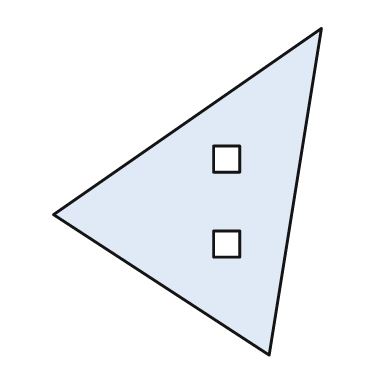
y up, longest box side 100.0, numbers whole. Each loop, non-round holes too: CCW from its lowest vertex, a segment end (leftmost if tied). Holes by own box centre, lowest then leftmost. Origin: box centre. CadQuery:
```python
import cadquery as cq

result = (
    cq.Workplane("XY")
    .moveTo(25.0, -50.0)
    .lineTo(41.0, 50.0)
    .lineTo(-41.0, -7.0)
    .close()
    .moveTo(8.0, -20.0)
    .lineTo(16.0, -20.0)
    .lineTo(16.0, -12.0)
    .lineTo(8.0, -12.0)
    .close()
    .moveTo(8.0, 6.0)
    .lineTo(16.0, 6.0)
    .lineTo(16.0, 14.0)
    .lineTo(8.0, 14.0)
    .close()
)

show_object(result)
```